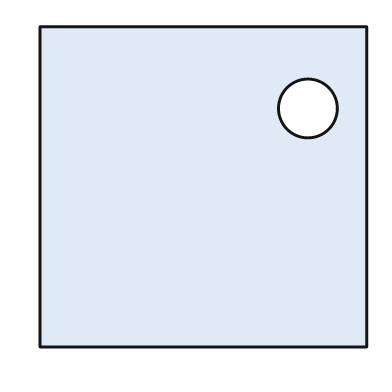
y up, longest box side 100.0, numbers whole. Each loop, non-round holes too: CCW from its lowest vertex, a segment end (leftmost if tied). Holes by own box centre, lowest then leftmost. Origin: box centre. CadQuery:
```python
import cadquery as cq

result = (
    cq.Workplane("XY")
    .moveTo(-50.0, -49.0)
    .lineTo(50.0, -49.0)
    .lineTo(50.0, 49.0)
    .lineTo(-50.0, 49.0)
    .close()
    .moveTo(32.0, 24.0)
    .circle(9.0)
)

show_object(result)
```